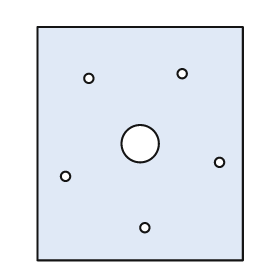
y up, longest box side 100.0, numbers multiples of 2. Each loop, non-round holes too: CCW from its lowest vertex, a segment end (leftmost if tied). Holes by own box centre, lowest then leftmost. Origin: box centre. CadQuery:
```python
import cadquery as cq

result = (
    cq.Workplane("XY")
    .moveTo(-44.0, -50.0)
    .lineTo(44.0, -50.0)
    .lineTo(44.0, 50.0)
    .lineTo(-44.0, 50.0)
    .close()
    .moveTo(2.0, -36.0)
    .circle(2.0)
    .moveTo(-32.0, -14.0)
    .circle(2.0)
    .moveTo(34.0, -8.0)
    .circle(2.0)
    .moveTo(0.0, 0.0)
    .circle(8.0)
    .moveTo(-22.0, 28.0)
    .circle(2.0)
    .moveTo(18.0, 30.0)
    .circle(2.0)
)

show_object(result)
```